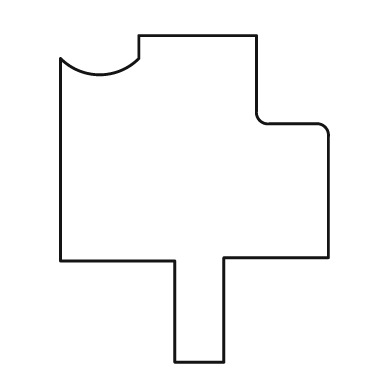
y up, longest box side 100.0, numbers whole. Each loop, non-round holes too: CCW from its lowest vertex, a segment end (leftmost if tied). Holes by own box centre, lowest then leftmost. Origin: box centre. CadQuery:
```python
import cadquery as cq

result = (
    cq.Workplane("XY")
    .moveTo(-6.0, -50.0)
    .lineTo(9.0, -50.0)
    .lineTo(9.0, -18.0)
    .lineTo(41.0, -18.0)
    .lineTo(41.0, 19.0)
    .threePointArc((40.0, 22.0), (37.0, 23.0))
    .lineTo(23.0, 23.0)
    .threePointArc((20.0, 24.0), (19.0, 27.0))
    .lineTo(19.0, 50.0)
    .lineTo(-17.0, 50.0)
    .lineTo(-17.0, 43.0)
    .threePointArc((-29.0, 38.0), (-41.0, 43.0))
    .lineTo(-41.0, -19.0)
    .lineTo(-6.0, -19.0)
    .close()
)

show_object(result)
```